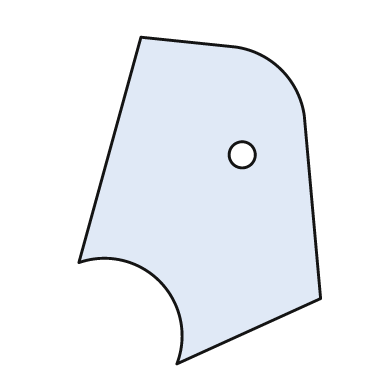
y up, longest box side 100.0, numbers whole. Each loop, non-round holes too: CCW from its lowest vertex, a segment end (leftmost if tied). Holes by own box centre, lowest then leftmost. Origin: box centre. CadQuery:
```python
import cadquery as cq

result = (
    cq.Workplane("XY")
    .moveTo(-7.0, -50.0)
    .lineTo(37.0, -30.0)
    .lineTo(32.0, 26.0)
    .threePointArc((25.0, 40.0), (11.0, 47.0))
    .lineTo(-18.0, 50.0)
    .lineTo(-37.0, -19.0)
    .threePointArc((-12.0, -25.0), (-7.0, -50.0))
    .close()
    .moveTo(13.0, 14.0)
    .circle(4.0)
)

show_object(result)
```